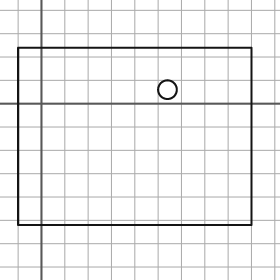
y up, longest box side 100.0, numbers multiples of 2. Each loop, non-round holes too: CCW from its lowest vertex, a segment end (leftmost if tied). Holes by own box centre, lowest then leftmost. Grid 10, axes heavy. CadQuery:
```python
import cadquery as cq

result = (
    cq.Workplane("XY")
    .moveTo(-10.0, -52.0)
    .lineTo(90.0, -52.0)
    .lineTo(90.0, 24.0)
    .lineTo(-10.0, 24.0)
    .close()
    .moveTo(54.0, 6.0)
    .circle(4.0)
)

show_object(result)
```